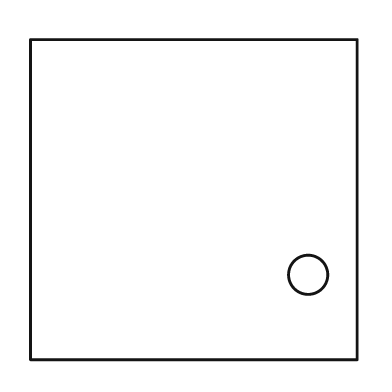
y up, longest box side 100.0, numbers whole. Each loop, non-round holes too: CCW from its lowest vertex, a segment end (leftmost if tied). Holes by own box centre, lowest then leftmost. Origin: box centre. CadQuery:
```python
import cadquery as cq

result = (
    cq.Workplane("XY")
    .moveTo(-50.0, -49.0)
    .lineTo(50.0, -49.0)
    .lineTo(50.0, 49.0)
    .lineTo(-50.0, 49.0)
    .close()
    .moveTo(35.0, -23.0)
    .circle(6.0)
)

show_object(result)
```